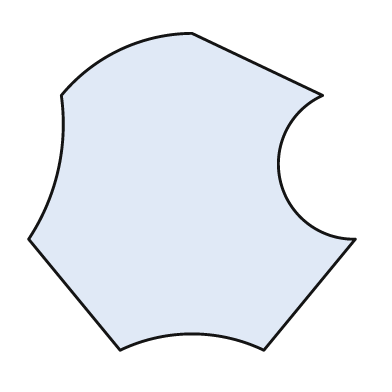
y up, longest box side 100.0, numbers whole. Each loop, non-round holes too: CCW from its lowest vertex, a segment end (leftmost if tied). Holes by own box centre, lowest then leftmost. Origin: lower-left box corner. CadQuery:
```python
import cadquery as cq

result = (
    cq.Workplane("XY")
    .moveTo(28.0, 0.0)
    .threePointArc((50.0, 5.0), (72.0, 0.0))
    .lineTo(100.0, 34.0)
    .threePointArc((77.0, 52.0), (90.0, 78.0))
    .lineTo(50.0, 97.0)
    .threePointArc((28.0, 92.0), (10.0, 78.0))
    .threePointArc((9.0, 55.0), (0.0, 34.0))
    .close()
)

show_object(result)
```